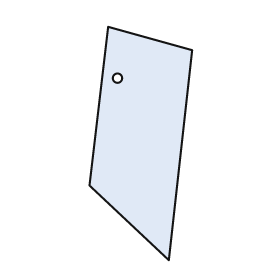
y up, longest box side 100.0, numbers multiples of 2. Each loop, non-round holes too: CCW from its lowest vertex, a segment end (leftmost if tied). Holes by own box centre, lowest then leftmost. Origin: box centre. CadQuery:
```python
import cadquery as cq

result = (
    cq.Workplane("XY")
    .moveTo(12.0, -50.0)
    .lineTo(22.0, 40.0)
    .lineTo(-14.0, 50.0)
    .lineTo(-22.0, -18.0)
    .close()
    .moveTo(-10.0, 28.0)
    .circle(2.0)
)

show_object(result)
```